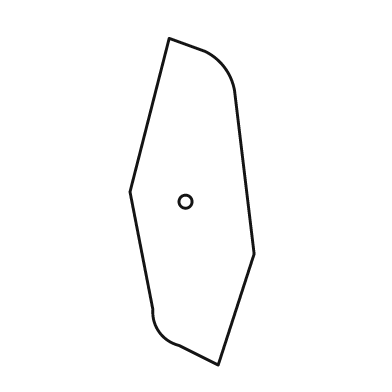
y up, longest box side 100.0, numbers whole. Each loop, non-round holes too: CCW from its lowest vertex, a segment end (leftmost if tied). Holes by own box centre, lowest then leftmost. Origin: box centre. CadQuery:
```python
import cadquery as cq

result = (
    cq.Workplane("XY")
    .moveTo(8.0, -50.0)
    .lineTo(19.0, -16.0)
    .lineTo(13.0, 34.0)
    .threePointArc((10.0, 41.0), (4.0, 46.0))
    .lineTo(-7.0, 50.0)
    .lineTo(-19.0, 3.0)
    .lineTo(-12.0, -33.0)
    .threePointArc((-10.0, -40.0), (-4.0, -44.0))
    .close()
    .moveTo(-2.0, 0.0)
    .circle(2.0)
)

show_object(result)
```